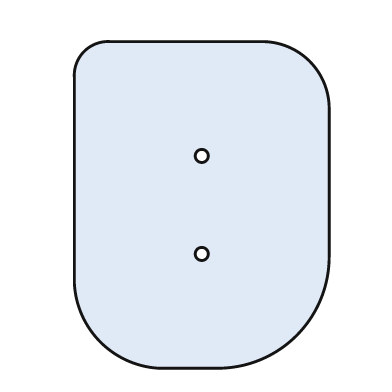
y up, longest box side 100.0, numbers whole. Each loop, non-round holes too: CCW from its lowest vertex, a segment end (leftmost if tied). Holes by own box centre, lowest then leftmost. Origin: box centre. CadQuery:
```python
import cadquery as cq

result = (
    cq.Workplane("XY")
    .moveTo(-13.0, -50.0)
    .lineTo(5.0, -50.0)
    .threePointArc((29.0, -40.0), (39.0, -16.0))
    .lineTo(39.0, 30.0)
    .threePointArc((33.0, 44.0), (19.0, 50.0))
    .lineTo(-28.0, 50.0)
    .threePointArc((-36.0, 47.0), (-39.0, 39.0))
    .lineTo(-39.0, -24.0)
    .threePointArc((-31.0, -42.0), (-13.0, -50.0))
    .close()
    .moveTo(0.0, -15.0)
    .circle(2.0)
    .moveTo(0.0, 15.0)
    .circle(2.0)
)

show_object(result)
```